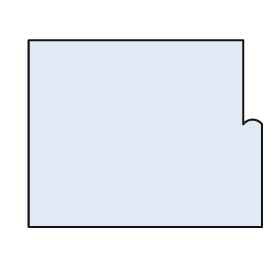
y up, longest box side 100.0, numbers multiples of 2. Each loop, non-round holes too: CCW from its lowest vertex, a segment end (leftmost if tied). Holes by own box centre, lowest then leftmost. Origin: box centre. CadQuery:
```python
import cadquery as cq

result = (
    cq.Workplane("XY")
    .moveTo(-50.0, -40.0)
    .lineTo(50.0, -40.0)
    .lineTo(50.0, 4.0)
    .threePointArc((46.0, 6.0), (42.0, 4.0))
    .lineTo(42.0, 40.0)
    .lineTo(-50.0, 40.0)
    .close()
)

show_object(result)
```